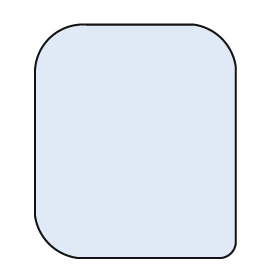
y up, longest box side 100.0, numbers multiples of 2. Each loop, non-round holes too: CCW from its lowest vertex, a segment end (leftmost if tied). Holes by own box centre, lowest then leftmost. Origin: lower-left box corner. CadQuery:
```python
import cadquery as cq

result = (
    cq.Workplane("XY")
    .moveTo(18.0, 0.0)
    .lineTo(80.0, 0.0)
    .threePointArc((84.0, 2.0), (86.0, 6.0))
    .lineTo(86.0, 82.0)
    .threePointArc((80.0, 94.0), (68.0, 100.0))
    .lineTo(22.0, 100.0)
    .threePointArc((6.0, 94.0), (0.0, 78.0))
    .lineTo(0.0, 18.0)
    .threePointArc((6.0, 6.0), (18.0, 0.0))
    .close()
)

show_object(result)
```